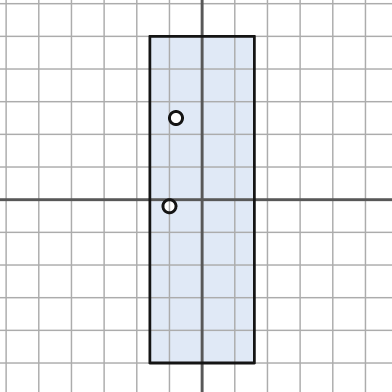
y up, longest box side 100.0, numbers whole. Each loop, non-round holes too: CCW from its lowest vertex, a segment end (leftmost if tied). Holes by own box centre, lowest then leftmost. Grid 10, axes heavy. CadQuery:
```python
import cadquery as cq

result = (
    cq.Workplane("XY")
    .moveTo(-16.0, -50.0)
    .lineTo(16.0, -50.0)
    .lineTo(16.0, 50.0)
    .lineTo(-16.0, 50.0)
    .close()
    .moveTo(-10.0, -2.0)
    .circle(2.0)
    .moveTo(-8.0, 25.0)
    .circle(2.0)
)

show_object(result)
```